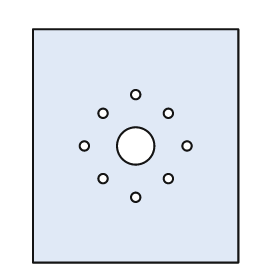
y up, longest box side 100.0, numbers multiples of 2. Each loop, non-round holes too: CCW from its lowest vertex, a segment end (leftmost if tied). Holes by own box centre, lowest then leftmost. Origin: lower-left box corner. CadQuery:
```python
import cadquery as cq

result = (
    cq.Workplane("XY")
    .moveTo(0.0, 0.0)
    .lineTo(88.0, 0.0)
    .lineTo(88.0, 100.0)
    .lineTo(0.0, 100.0)
    .close()
    .moveTo(44.0, 28.0)
    .circle(2.0)
    .moveTo(30.0, 36.0)
    .circle(2.0)
    .moveTo(58.0, 36.0)
    .circle(2.0)
    .moveTo(22.0, 50.0)
    .circle(2.0)
    .moveTo(44.0, 50.0)
    .circle(8.0)
    .moveTo(66.0, 50.0)
    .circle(2.0)
    .moveTo(30.0, 64.0)
    .circle(2.0)
    .moveTo(58.0, 64.0)
    .circle(2.0)
    .moveTo(44.0, 72.0)
    .circle(2.0)
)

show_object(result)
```